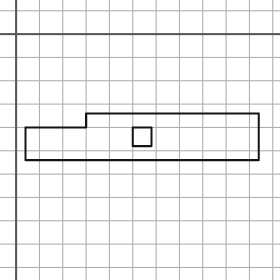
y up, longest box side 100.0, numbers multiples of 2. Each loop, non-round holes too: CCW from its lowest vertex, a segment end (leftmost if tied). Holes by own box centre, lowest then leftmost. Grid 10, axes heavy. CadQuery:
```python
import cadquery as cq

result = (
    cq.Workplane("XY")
    .moveTo(4.0, -54.0)
    .lineTo(104.0, -54.0)
    .lineTo(104.0, -34.0)
    .lineTo(30.0, -34.0)
    .lineTo(30.0, -40.0)
    .lineTo(4.0, -40.0)
    .close()
    .moveTo(50.0, -48.0)
    .lineTo(58.0, -48.0)
    .lineTo(58.0, -40.0)
    .lineTo(50.0, -40.0)
    .close()
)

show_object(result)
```